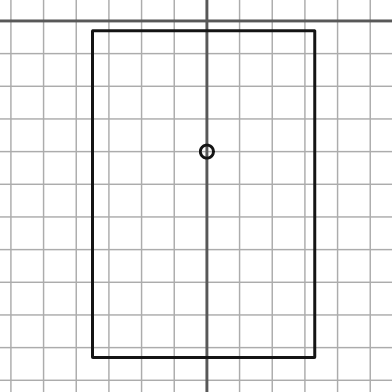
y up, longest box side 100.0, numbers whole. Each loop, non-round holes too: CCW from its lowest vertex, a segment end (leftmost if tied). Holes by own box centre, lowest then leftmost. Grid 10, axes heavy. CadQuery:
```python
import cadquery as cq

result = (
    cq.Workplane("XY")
    .moveTo(-35.0, -103.0)
    .lineTo(33.0, -103.0)
    .lineTo(33.0, -3.0)
    .lineTo(-35.0, -3.0)
    .close()
    .moveTo(0.0, -40.0)
    .circle(2.0)
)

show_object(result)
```